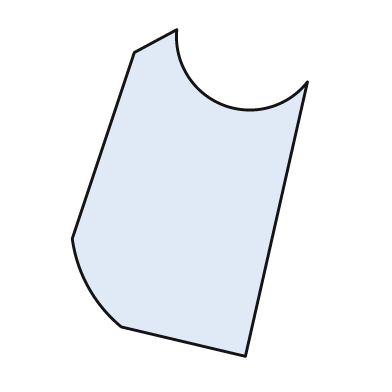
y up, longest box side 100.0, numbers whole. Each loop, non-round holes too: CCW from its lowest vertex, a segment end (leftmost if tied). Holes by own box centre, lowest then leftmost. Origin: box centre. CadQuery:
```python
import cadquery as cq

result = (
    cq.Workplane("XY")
    .moveTo(17.0, -50.0)
    .lineTo(36.0, 34.0)
    .threePointArc((10.0, 27.0), (-4.0, 50.0))
    .lineTo(-17.0, 43.0)
    .lineTo(-36.0, -14.0)
    .threePointArc((-31.0, -29.0), (-21.0, -41.0))
    .close()
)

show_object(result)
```